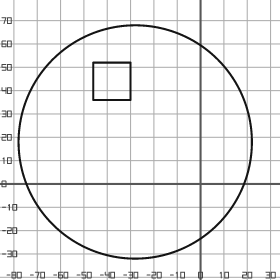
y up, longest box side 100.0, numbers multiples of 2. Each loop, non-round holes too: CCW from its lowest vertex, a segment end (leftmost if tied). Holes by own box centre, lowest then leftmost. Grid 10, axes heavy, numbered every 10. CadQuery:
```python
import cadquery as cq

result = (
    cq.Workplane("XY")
    .moveTo(-28.0, 18.0)
    .circle(50.0)
    .moveTo(-46.0, 36.0)
    .lineTo(-30.0, 36.0)
    .lineTo(-30.0, 52.0)
    .lineTo(-46.0, 52.0)
    .close()
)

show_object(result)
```